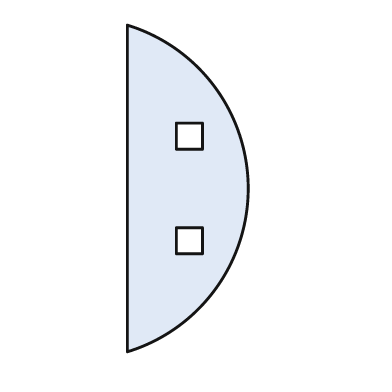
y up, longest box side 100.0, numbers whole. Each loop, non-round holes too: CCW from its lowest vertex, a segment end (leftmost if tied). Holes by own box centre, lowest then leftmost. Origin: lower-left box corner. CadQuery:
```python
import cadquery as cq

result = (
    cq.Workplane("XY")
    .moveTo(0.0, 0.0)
    .threePointArc((37.0, 50.0), (0.0, 100.0))
    .close()
    .moveTo(15.0, 30.0)
    .lineTo(23.0, 30.0)
    .lineTo(23.0, 38.0)
    .lineTo(15.0, 38.0)
    .close()
    .moveTo(15.0, 62.0)
    .lineTo(23.0, 62.0)
    .lineTo(23.0, 70.0)
    .lineTo(15.0, 70.0)
    .close()
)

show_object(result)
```